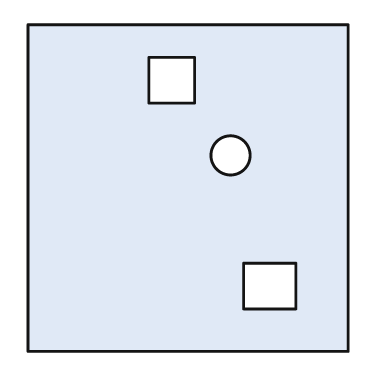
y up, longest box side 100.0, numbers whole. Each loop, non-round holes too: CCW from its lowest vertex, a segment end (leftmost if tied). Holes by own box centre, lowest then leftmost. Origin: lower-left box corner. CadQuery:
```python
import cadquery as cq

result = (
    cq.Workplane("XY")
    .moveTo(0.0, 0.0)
    .lineTo(98.0, 0.0)
    .lineTo(98.0, 100.0)
    .lineTo(0.0, 100.0)
    .close()
    .moveTo(66.0, 13.0)
    .lineTo(82.0, 13.0)
    .lineTo(82.0, 27.0)
    .lineTo(66.0, 27.0)
    .close()
    .moveTo(62.0, 60.0)
    .circle(6.0)
    .moveTo(37.0, 76.0)
    .lineTo(51.0, 76.0)
    .lineTo(51.0, 90.0)
    .lineTo(37.0, 90.0)
    .close()
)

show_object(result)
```